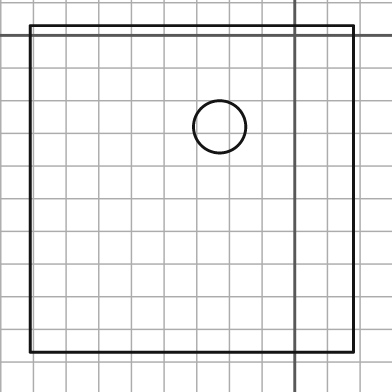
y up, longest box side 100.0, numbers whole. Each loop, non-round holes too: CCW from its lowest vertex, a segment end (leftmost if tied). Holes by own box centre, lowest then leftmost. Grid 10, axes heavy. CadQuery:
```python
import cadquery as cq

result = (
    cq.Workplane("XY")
    .moveTo(-81.0, -97.0)
    .lineTo(18.0, -97.0)
    .lineTo(18.0, 3.0)
    .lineTo(-81.0, 3.0)
    .close()
    .moveTo(-23.0, -28.0)
    .circle(8.0)
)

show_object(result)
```